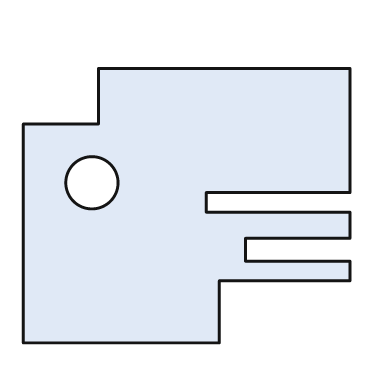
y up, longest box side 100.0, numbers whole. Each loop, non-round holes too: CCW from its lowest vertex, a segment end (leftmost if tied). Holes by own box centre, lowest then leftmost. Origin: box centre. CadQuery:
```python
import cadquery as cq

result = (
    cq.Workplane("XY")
    .moveTo(-50.0, -42.0)
    .lineTo(10.0, -42.0)
    .lineTo(10.0, -23.0)
    .lineTo(50.0, -23.0)
    .lineTo(50.0, -17.0)
    .lineTo(18.0, -17.0)
    .lineTo(18.0, -10.0)
    .lineTo(50.0, -10.0)
    .lineTo(50.0, -2.0)
    .lineTo(6.0, -2.0)
    .lineTo(6.0, 4.0)
    .lineTo(50.0, 4.0)
    .lineTo(50.0, 42.0)
    .lineTo(-27.0, 42.0)
    .lineTo(-27.0, 25.0)
    .lineTo(-50.0, 25.0)
    .close()
    .moveTo(-29.0, 7.0)
    .circle(8.0)
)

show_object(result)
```